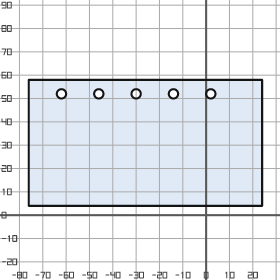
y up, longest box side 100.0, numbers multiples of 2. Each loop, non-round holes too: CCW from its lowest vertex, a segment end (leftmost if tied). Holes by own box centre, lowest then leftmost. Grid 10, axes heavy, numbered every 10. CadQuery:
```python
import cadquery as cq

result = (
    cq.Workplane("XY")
    .moveTo(-76.0, 4.0)
    .lineTo(24.0, 4.0)
    .lineTo(24.0, 58.0)
    .lineTo(-76.0, 58.0)
    .close()
    .moveTo(-62.0, 52.0)
    .circle(2.0)
    .moveTo(-46.0, 52.0)
    .circle(2.0)
    .moveTo(-30.0, 52.0)
    .circle(2.0)
    .moveTo(-14.0, 52.0)
    .circle(2.0)
    .moveTo(2.0, 52.0)
    .circle(2.0)
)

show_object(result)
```